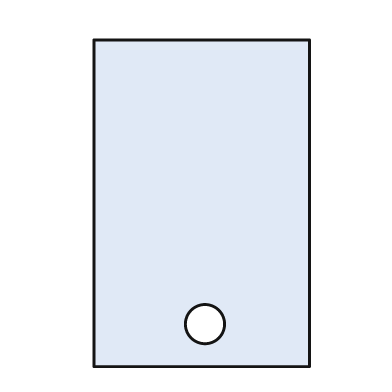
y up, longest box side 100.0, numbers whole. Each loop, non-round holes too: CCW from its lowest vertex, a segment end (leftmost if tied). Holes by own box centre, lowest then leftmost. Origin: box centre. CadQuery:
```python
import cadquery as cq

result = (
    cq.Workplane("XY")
    .moveTo(-33.0, -50.0)
    .lineTo(33.0, -50.0)
    .lineTo(33.0, 50.0)
    .lineTo(-33.0, 50.0)
    .close()
    .moveTo(1.0, -37.0)
    .circle(6.0)
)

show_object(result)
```